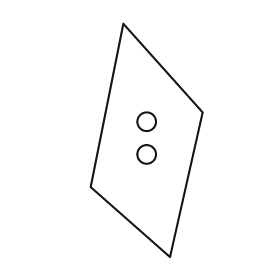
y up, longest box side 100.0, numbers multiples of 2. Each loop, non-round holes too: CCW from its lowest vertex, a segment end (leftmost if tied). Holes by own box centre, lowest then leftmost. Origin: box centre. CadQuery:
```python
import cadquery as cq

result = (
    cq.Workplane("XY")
    .moveTo(10.0, -50.0)
    .lineTo(24.0, 12.0)
    .lineTo(-10.0, 50.0)
    .lineTo(-24.0, -20.0)
    .close()
    .moveTo(0.0, -6.0)
    .circle(4.0)
    .moveTo(0.0, 8.0)
    .circle(4.0)
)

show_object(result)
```